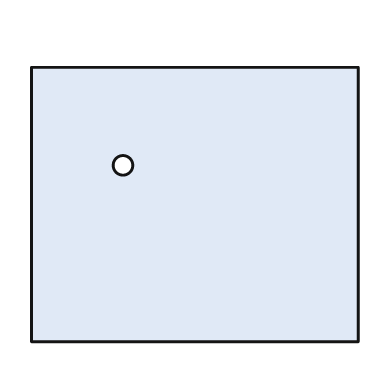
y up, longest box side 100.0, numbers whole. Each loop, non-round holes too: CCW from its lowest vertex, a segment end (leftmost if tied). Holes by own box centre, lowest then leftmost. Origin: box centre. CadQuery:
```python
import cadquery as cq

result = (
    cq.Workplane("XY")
    .moveTo(-50.0, -42.0)
    .lineTo(50.0, -42.0)
    .lineTo(50.0, 42.0)
    .lineTo(-50.0, 42.0)
    .close()
    .moveTo(-22.0, 12.0)
    .circle(3.0)
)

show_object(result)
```